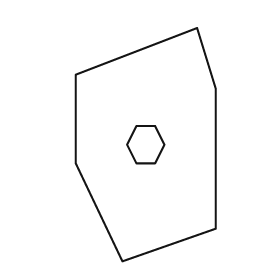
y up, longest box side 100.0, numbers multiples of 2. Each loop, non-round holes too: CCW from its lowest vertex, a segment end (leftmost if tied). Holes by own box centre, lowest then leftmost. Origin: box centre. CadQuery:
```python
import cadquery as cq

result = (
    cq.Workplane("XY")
    .moveTo(-10.0, -50.0)
    .lineTo(30.0, -36.0)
    .lineTo(30.0, 24.0)
    .lineTo(22.0, 50.0)
    .lineTo(-30.0, 30.0)
    .lineTo(-30.0, -8.0)
    .close()
    .moveTo(-4.0, -8.0)
    .lineTo(4.0, -8.0)
    .lineTo(8.0, 0.0)
    .lineTo(4.0, 8.0)
    .lineTo(-4.0, 8.0)
    .lineTo(-8.0, 0.0)
    .close()
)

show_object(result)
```